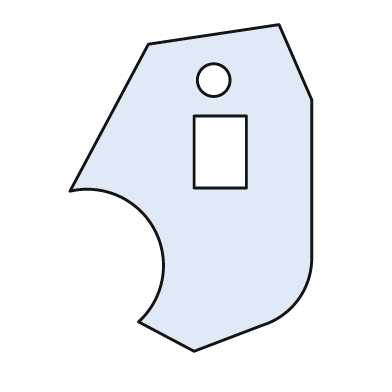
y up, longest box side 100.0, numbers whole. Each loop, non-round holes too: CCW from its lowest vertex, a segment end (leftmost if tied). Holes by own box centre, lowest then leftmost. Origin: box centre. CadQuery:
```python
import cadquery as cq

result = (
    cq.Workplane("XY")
    .moveTo(1.0, -50.0)
    .lineTo(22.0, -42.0)
    .threePointArc((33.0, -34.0), (37.0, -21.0))
    .lineTo(37.0, 27.0)
    .lineTo(27.0, 50.0)
    .lineTo(-13.0, 44.0)
    .lineTo(-37.0, -1.0)
    .threePointArc((-11.0, -13.0), (-16.0, -41.0))
    .close()
    .moveTo(1.0, 0.0)
    .lineTo(17.0, 0.0)
    .lineTo(17.0, 22.0)
    .lineTo(1.0, 22.0)
    .close()
    .moveTo(7.0, 33.0)
    .circle(5.0)
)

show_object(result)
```